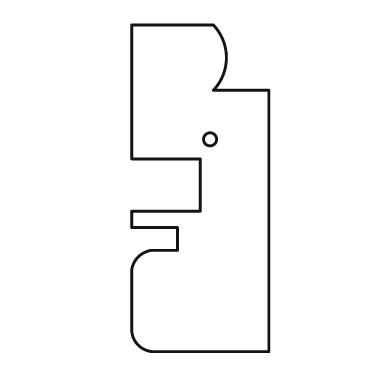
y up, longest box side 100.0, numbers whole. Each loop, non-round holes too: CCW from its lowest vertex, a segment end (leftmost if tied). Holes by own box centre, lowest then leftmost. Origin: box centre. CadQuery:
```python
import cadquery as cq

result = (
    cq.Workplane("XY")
    .moveTo(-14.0, -50.0)
    .lineTo(21.0, -50.0)
    .lineTo(21.0, 30.0)
    .lineTo(4.0, 30.0)
    .threePointArc((8.0, 40.0), (4.0, 50.0))
    .lineTo(-21.0, 50.0)
    .lineTo(-21.0, 9.0)
    .lineTo(0.0, 9.0)
    .lineTo(0.0, -7.0)
    .lineTo(-21.0, -7.0)
    .lineTo(-21.0, -12.0)
    .lineTo(-7.0, -12.0)
    .lineTo(-7.0, -19.0)
    .lineTo(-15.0, -19.0)
    .threePointArc((-19.0, -21.0), (-21.0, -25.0))
    .lineTo(-21.0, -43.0)
    .threePointArc((-19.0, -48.0), (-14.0, -50.0))
    .close()
    .moveTo(3.0, 15.0)
    .circle(2.0)
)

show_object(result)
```